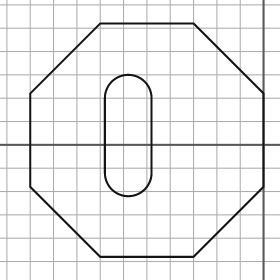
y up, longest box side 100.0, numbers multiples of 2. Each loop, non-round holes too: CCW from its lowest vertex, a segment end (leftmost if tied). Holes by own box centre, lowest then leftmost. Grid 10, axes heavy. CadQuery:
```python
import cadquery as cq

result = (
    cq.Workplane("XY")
    .moveTo(-70.0, -48.0)
    .lineTo(-30.0, -48.0)
    .lineTo(0.0, -18.0)
    .lineTo(0.0, 22.0)
    .lineTo(-30.0, 52.0)
    .lineTo(-70.0, 52.0)
    .lineTo(-100.0, 22.0)
    .lineTo(-100.0, -18.0)
    .close()
    .moveTo(-68.0, -12.0)
    .threePointArc((-58.0, -22.0), (-48.0, -12.0))
    .lineTo(-48.0, 20.0)
    .threePointArc((-58.0, 30.0), (-68.0, 20.0))
    .close()
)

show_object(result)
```